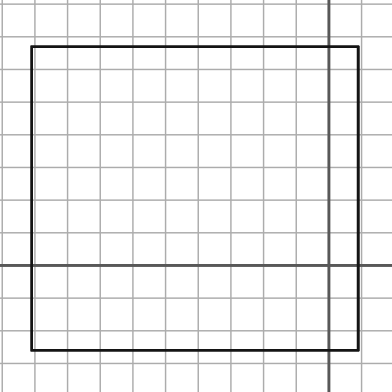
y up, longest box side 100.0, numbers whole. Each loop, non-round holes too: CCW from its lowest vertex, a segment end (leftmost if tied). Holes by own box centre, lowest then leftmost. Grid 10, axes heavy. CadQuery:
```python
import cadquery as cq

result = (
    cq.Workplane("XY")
    .moveTo(-91.0, -26.0)
    .lineTo(9.0, -26.0)
    .lineTo(9.0, 67.0)
    .lineTo(-91.0, 67.0)
    .close()
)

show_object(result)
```